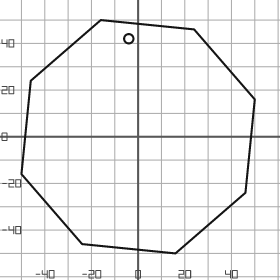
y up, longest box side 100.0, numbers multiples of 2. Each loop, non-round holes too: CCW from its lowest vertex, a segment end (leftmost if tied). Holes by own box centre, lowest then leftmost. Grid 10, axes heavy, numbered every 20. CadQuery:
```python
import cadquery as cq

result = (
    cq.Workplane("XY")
    .moveTo(16.0, -50.0)
    .lineTo(46.0, -24.0)
    .lineTo(50.0, 16.0)
    .lineTo(24.0, 46.0)
    .lineTo(-16.0, 50.0)
    .lineTo(-46.0, 24.0)
    .lineTo(-50.0, -16.0)
    .lineTo(-24.0, -46.0)
    .close()
    .moveTo(-4.0, 42.0)
    .circle(2.0)
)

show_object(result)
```